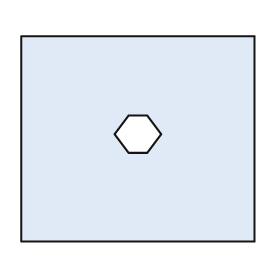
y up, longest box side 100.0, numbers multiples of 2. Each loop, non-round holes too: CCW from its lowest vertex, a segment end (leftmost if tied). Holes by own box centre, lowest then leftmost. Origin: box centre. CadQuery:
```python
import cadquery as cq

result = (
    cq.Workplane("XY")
    .moveTo(-50.0, -44.0)
    .lineTo(50.0, -44.0)
    .lineTo(50.0, 44.0)
    .lineTo(-50.0, 44.0)
    .close()
    .moveTo(-4.0, -6.0)
    .lineTo(4.0, -6.0)
    .lineTo(10.0, 2.0)
    .lineTo(4.0, 10.0)
    .lineTo(-4.0, 10.0)
    .lineTo(-10.0, 2.0)
    .close()
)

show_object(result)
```